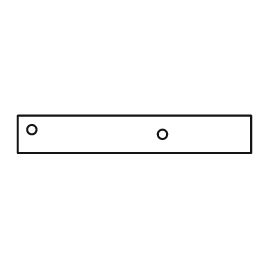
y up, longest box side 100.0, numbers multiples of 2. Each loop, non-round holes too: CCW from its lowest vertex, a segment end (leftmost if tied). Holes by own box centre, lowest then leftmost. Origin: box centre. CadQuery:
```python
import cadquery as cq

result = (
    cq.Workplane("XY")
    .moveTo(-50.0, -8.0)
    .lineTo(50.0, -8.0)
    .lineTo(50.0, 8.0)
    .lineTo(-50.0, 8.0)
    .close()
    .moveTo(12.0, 0.0)
    .circle(2.0)
    .moveTo(-44.0, 2.0)
    .circle(2.0)
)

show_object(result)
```